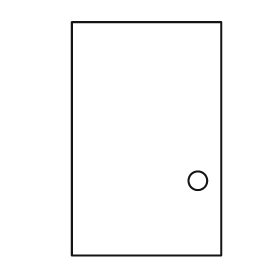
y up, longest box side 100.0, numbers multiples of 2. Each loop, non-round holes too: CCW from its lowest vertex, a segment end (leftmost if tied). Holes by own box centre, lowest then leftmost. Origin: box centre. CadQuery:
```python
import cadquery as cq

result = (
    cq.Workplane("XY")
    .moveTo(-32.0, -50.0)
    .lineTo(32.0, -50.0)
    .lineTo(32.0, 50.0)
    .lineTo(-32.0, 50.0)
    .close()
    .moveTo(22.0, -18.0)
    .circle(4.0)
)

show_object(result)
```